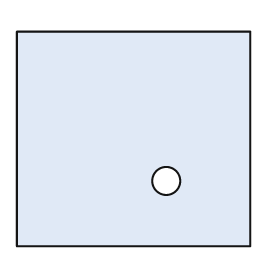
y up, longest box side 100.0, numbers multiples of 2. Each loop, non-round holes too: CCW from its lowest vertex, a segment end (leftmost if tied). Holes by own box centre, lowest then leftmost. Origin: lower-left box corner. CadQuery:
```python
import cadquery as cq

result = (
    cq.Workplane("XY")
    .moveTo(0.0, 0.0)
    .lineTo(100.0, 0.0)
    .lineTo(100.0, 92.0)
    .lineTo(0.0, 92.0)
    .close()
    .moveTo(64.0, 28.0)
    .circle(6.0)
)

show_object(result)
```